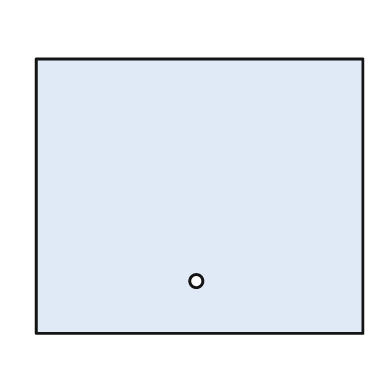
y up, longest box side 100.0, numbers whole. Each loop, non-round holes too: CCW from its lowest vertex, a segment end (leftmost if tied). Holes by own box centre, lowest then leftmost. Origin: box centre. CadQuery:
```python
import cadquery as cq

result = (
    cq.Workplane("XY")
    .moveTo(-50.0, -42.0)
    .lineTo(50.0, -42.0)
    .lineTo(50.0, 42.0)
    .lineTo(-50.0, 42.0)
    .close()
    .moveTo(-1.0, -26.0)
    .circle(2.0)
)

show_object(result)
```